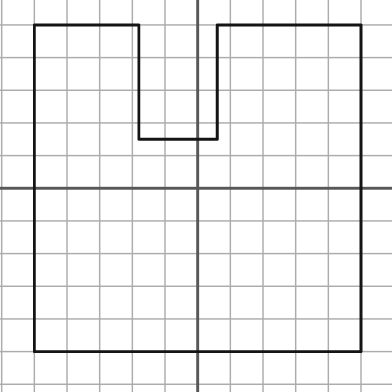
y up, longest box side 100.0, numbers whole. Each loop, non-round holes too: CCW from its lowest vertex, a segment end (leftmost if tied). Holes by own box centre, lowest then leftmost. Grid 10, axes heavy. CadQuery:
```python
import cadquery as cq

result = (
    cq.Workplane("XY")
    .moveTo(-50.0, -50.0)
    .lineTo(50.0, -50.0)
    .lineTo(50.0, 50.0)
    .lineTo(6.0, 50.0)
    .lineTo(6.0, 15.0)
    .lineTo(-18.0, 15.0)
    .lineTo(-18.0, 50.0)
    .lineTo(-50.0, 50.0)
    .close()
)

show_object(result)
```